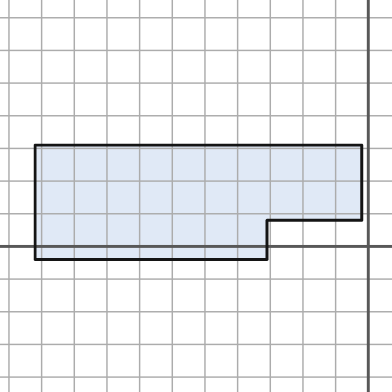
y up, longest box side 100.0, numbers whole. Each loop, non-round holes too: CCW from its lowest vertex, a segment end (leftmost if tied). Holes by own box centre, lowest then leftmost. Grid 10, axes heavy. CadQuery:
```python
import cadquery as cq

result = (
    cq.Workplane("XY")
    .moveTo(-102.0, -4.0)
    .lineTo(-31.0, -4.0)
    .lineTo(-31.0, 8.0)
    .lineTo(-2.0, 8.0)
    .lineTo(-2.0, 31.0)
    .lineTo(-102.0, 31.0)
    .close()
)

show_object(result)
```